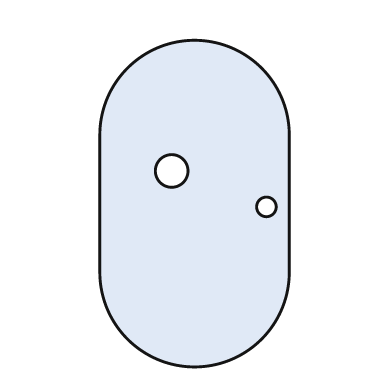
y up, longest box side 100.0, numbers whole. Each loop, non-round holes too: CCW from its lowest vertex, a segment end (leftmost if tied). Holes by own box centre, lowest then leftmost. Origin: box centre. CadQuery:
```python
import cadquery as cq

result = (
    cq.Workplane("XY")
    .moveTo(-29.0, -21.0)
    .threePointArc((0.0, -50.0), (29.0, -21.0))
    .lineTo(29.0, 21.0)
    .threePointArc((0.0, 50.0), (-29.0, 21.0))
    .close()
    .moveTo(22.0, -1.0)
    .circle(3.0)
    .moveTo(-7.0, 10.0)
    .circle(5.0)
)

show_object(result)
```